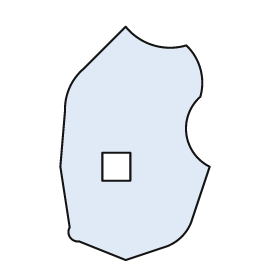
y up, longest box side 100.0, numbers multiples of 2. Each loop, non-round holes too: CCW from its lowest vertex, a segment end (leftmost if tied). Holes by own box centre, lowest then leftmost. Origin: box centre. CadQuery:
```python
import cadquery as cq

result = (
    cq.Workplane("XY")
    .moveTo(-4.0, -50.0)
    .lineTo(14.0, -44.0)
    .threePointArc((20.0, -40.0), (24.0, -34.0))
    .lineTo(32.0, -10.0)
    .threePointArc((22.0, 4.0), (28.0, 20.0))
    .threePointArc((28.0, 32.0), (22.0, 42.0))
    .threePointArc((8.0, 42.0), (-4.0, 50.0))
    .lineTo(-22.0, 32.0)
    .threePointArc((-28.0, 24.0), (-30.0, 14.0))
    .lineTo(-32.0, -10.0)
    .lineTo(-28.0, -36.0)
    .threePointArc((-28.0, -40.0), (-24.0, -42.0))
    .close()
    .moveTo(-14.0, -16.0)
    .lineTo(-2.0, -16.0)
    .lineTo(-2.0, -4.0)
    .lineTo(-14.0, -4.0)
    .close()
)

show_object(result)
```